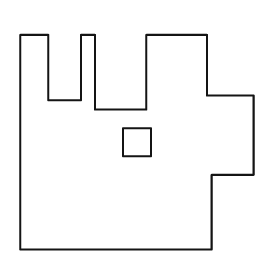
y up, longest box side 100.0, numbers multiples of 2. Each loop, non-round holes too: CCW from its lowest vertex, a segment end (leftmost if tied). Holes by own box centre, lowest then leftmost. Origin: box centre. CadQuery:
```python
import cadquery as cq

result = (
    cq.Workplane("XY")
    .moveTo(-50.0, -46.0)
    .lineTo(32.0, -46.0)
    .lineTo(32.0, -14.0)
    .lineTo(50.0, -14.0)
    .lineTo(50.0, 20.0)
    .lineTo(30.0, 20.0)
    .lineTo(30.0, 46.0)
    .lineTo(4.0, 46.0)
    .lineTo(4.0, 14.0)
    .lineTo(-18.0, 14.0)
    .lineTo(-18.0, 46.0)
    .lineTo(-24.0, 46.0)
    .lineTo(-24.0, 18.0)
    .lineTo(-38.0, 18.0)
    .lineTo(-38.0, 46.0)
    .lineTo(-50.0, 46.0)
    .close()
    .moveTo(-6.0, -6.0)
    .lineTo(6.0, -6.0)
    .lineTo(6.0, 6.0)
    .lineTo(-6.0, 6.0)
    .close()
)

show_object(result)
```